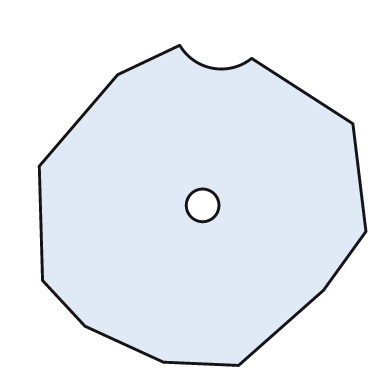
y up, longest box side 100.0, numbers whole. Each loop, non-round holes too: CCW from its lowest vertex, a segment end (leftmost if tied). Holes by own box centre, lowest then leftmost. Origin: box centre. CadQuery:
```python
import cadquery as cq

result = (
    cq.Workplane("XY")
    .moveTo(11.0, -49.0)
    .lineTo(37.0, -26.0)
    .lineTo(50.0, -8.0)
    .lineTo(46.0, 25.0)
    .lineTo(15.0, 45.0)
    .threePointArc((3.0, 42.0), (-7.0, 49.0))
    .lineTo(-26.0, 40.0)
    .lineTo(-50.0, 12.0)
    .lineTo(-49.0, -23.0)
    .lineTo(-36.0, -37.0)
    .lineTo(-12.0, -48.0)
    .close()
    .moveTo(0.0, 0.0)
    .circle(5.0)
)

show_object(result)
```